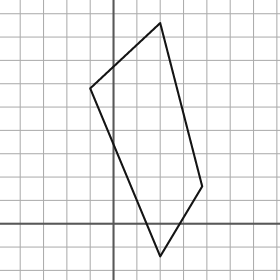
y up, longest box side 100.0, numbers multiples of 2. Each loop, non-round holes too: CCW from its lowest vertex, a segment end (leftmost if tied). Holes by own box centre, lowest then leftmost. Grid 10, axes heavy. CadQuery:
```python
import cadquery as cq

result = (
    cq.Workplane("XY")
    .moveTo(20.0, -14.0)
    .lineTo(38.0, 16.0)
    .lineTo(20.0, 86.0)
    .lineTo(-10.0, 58.0)
    .close()
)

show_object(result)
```